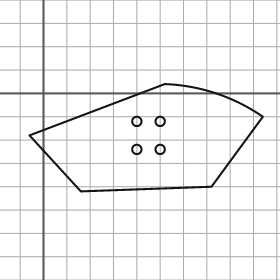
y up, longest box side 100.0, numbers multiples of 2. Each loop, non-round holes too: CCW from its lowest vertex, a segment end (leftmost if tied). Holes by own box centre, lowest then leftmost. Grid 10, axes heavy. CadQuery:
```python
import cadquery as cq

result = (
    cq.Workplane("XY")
    .moveTo(16.0, -42.0)
    .lineTo(72.0, -40.0)
    .lineTo(94.0, -10.0)
    .threePointArc((74.0, 0.0), (52.0, 4.0))
    .lineTo(-6.0, -18.0)
    .close()
    .moveTo(40.0, -24.0)
    .circle(2.0)
    .moveTo(50.0, -24.0)
    .circle(2.0)
    .moveTo(40.0, -12.0)
    .circle(2.0)
    .moveTo(50.0, -12.0)
    .circle(2.0)
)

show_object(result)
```